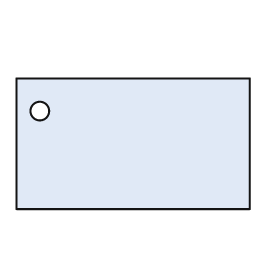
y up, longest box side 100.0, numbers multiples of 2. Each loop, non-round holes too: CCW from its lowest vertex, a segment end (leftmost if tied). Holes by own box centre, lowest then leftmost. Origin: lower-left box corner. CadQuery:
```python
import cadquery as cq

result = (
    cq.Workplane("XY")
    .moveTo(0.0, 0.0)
    .lineTo(100.0, 0.0)
    .lineTo(100.0, 56.0)
    .lineTo(0.0, 56.0)
    .close()
    .moveTo(10.0, 42.0)
    .circle(4.0)
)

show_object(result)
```